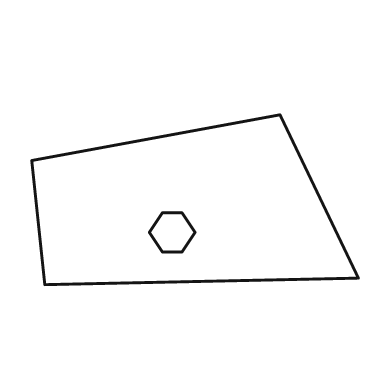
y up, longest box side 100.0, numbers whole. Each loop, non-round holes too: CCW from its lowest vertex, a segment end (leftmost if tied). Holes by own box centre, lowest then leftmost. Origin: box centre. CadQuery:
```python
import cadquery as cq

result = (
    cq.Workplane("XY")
    .moveTo(-46.0, -26.0)
    .lineTo(50.0, -24.0)
    .lineTo(26.0, 26.0)
    .lineTo(-50.0, 12.0)
    .close()
    .moveTo(-10.0, -16.0)
    .lineTo(-4.0, -16.0)
    .lineTo(0.0, -10.0)
    .lineTo(-4.0, -4.0)
    .lineTo(-10.0, -4.0)
    .lineTo(-14.0, -10.0)
    .close()
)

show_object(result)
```